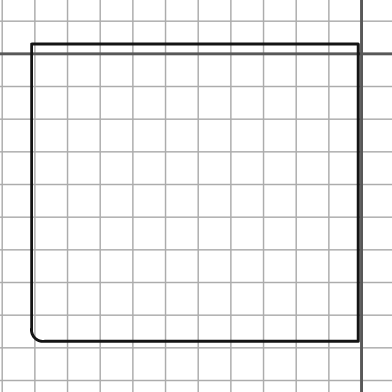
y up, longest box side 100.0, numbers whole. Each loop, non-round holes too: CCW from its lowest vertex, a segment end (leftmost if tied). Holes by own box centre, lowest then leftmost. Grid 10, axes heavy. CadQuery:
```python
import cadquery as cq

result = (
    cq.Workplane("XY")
    .moveTo(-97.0, -88.0)
    .lineTo(-1.0, -88.0)
    .lineTo(-1.0, 3.0)
    .lineTo(-101.0, 3.0)
    .lineTo(-101.0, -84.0)
    .threePointArc((-100.0, -87.0), (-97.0, -88.0))
    .close()
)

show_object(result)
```